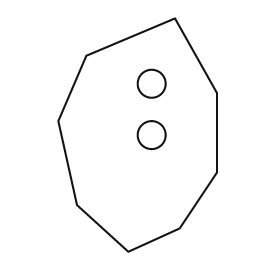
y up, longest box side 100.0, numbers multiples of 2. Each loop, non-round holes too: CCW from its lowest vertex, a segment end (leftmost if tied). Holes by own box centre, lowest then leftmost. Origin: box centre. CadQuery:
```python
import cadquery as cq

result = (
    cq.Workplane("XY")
    .moveTo(-4.0, -50.0)
    .lineTo(18.0, -40.0)
    .lineTo(34.0, -16.0)
    .lineTo(34.0, 18.0)
    .lineTo(16.0, 50.0)
    .lineTo(-22.0, 34.0)
    .lineTo(-34.0, 6.0)
    .lineTo(-26.0, -30.0)
    .close()
    .moveTo(6.0, 0.0)
    .circle(6.0)
    .moveTo(6.0, 22.0)
    .circle(6.0)
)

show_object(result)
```